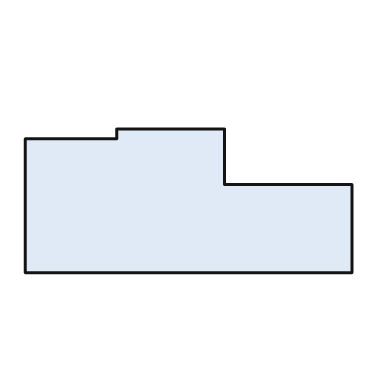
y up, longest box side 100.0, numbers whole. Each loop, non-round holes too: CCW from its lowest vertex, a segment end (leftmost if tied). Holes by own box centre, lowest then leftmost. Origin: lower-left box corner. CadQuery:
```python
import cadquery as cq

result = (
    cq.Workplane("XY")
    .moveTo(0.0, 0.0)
    .lineTo(100.0, 0.0)
    .lineTo(100.0, 27.0)
    .lineTo(61.0, 27.0)
    .lineTo(61.0, 44.0)
    .lineTo(28.0, 44.0)
    .lineTo(28.0, 41.0)
    .lineTo(0.0, 41.0)
    .close()
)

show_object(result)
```